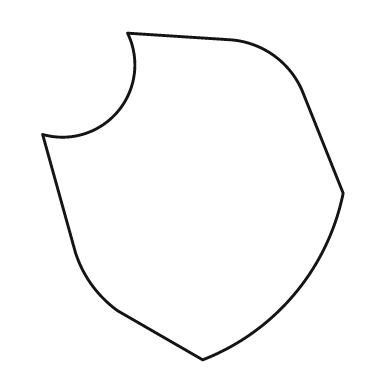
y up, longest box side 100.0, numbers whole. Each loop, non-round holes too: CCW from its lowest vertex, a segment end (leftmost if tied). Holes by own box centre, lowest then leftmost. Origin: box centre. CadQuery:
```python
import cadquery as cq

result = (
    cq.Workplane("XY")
    .moveTo(3.0, -50.0)
    .threePointArc((31.0, -30.0), (46.0, 1.0))
    .lineTo(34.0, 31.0)
    .threePointArc((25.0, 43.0), (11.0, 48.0))
    .lineTo(-20.0, 50.0)
    .threePointArc((-23.0, 26.0), (-46.0, 19.0))
    .lineTo(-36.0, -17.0)
    .threePointArc((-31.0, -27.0), (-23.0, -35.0))
    .close()
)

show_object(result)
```